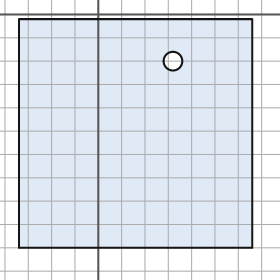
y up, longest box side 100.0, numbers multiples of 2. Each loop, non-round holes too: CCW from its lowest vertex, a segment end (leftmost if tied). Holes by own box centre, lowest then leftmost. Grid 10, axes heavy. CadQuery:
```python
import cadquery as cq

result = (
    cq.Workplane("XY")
    .moveTo(-34.0, -100.0)
    .lineTo(66.0, -100.0)
    .lineTo(66.0, -2.0)
    .lineTo(-34.0, -2.0)
    .close()
    .moveTo(32.0, -20.0)
    .circle(4.0)
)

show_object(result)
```